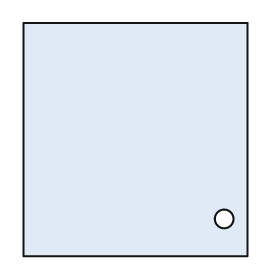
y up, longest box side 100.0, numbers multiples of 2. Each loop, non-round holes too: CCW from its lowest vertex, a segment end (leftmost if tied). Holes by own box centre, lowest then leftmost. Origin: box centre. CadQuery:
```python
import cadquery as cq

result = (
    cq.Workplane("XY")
    .moveTo(-48.0, -50.0)
    .lineTo(48.0, -50.0)
    .lineTo(48.0, 50.0)
    .lineTo(-48.0, 50.0)
    .close()
    .moveTo(38.0, -34.0)
    .circle(4.0)
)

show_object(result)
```